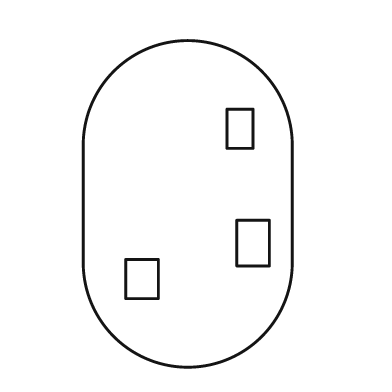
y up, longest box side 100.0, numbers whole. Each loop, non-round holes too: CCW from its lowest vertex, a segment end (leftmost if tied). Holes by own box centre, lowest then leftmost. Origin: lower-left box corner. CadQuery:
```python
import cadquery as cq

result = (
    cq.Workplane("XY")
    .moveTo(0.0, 32.0)
    .threePointArc((32.0, 0.0), (64.0, 32.0))
    .lineTo(64.0, 68.0)
    .threePointArc((32.0, 100.0), (0.0, 68.0))
    .close()
    .moveTo(13.0, 21.0)
    .lineTo(23.0, 21.0)
    .lineTo(23.0, 33.0)
    .lineTo(13.0, 33.0)
    .close()
    .moveTo(47.0, 31.0)
    .lineTo(57.0, 31.0)
    .lineTo(57.0, 45.0)
    .lineTo(47.0, 45.0)
    .close()
    .moveTo(44.0, 67.0)
    .lineTo(52.0, 67.0)
    .lineTo(52.0, 79.0)
    .lineTo(44.0, 79.0)
    .close()
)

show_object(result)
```